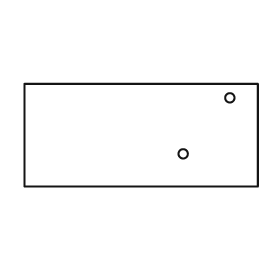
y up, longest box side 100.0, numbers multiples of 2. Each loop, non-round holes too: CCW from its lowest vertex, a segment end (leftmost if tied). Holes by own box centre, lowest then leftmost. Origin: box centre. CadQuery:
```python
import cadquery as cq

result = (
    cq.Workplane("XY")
    .moveTo(-50.0, -22.0)
    .lineTo(50.0, -22.0)
    .lineTo(50.0, 22.0)
    .lineTo(-50.0, 22.0)
    .close()
    .moveTo(18.0, -8.0)
    .circle(2.0)
    .moveTo(38.0, 16.0)
    .circle(2.0)
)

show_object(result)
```